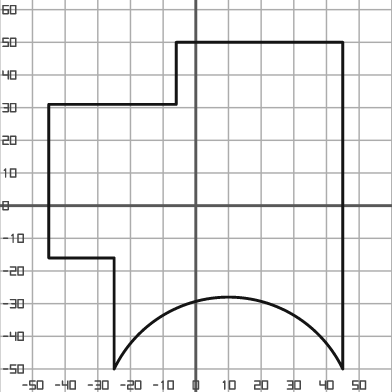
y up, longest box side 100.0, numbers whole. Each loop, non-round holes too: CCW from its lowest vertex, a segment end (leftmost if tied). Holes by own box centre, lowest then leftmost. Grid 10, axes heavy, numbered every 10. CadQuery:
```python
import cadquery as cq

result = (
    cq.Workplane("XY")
    .moveTo(-25.0, -50.0)
    .threePointArc((10.0, -28.0), (45.0, -50.0))
    .lineTo(45.0, 50.0)
    .lineTo(-6.0, 50.0)
    .lineTo(-6.0, 31.0)
    .lineTo(-45.0, 31.0)
    .lineTo(-45.0, -16.0)
    .lineTo(-25.0, -16.0)
    .close()
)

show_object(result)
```